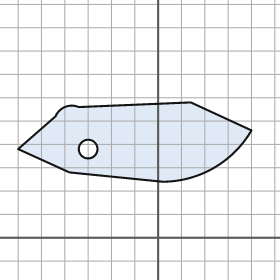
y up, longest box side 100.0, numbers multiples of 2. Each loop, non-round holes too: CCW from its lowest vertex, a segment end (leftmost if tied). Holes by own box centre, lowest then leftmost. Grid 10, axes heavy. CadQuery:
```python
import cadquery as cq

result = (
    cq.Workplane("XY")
    .moveTo(2.0, 24.0)
    .threePointArc((24.0, 30.0), (40.0, 46.0))
    .lineTo(14.0, 58.0)
    .lineTo(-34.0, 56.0)
    .threePointArc((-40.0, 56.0), (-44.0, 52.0))
    .lineTo(-60.0, 38.0)
    .lineTo(-38.0, 28.0)
    .close()
    .moveTo(-30.0, 38.0)
    .circle(4.0)
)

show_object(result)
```